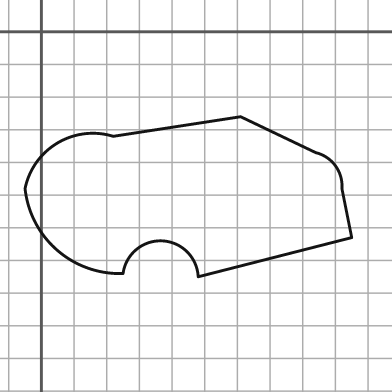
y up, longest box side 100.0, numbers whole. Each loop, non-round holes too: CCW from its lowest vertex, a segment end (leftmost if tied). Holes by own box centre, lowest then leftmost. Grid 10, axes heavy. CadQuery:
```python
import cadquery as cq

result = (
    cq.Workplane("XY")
    .moveTo(48.0, -75.0)
    .lineTo(95.0, -63.0)
    .lineTo(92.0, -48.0)
    .threePointArc((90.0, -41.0), (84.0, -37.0))
    .lineTo(61.0, -26.0)
    .lineTo(22.0, -32.0)
    .threePointArc((5.0, -34.0), (-5.0, -48.0))
    .threePointArc((5.0, -67.0), (25.0, -74.0))
    .threePointArc((37.0, -64.0), (48.0, -75.0))
    .close()
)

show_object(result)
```